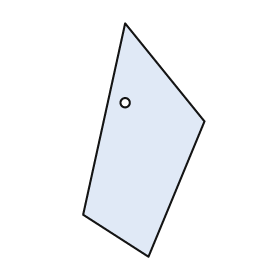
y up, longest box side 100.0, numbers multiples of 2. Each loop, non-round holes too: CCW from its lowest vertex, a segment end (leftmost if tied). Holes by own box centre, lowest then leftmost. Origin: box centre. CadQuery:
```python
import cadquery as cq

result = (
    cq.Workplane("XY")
    .moveTo(2.0, -50.0)
    .lineTo(26.0, 8.0)
    .lineTo(-8.0, 50.0)
    .lineTo(-26.0, -32.0)
    .close()
    .moveTo(-8.0, 16.0)
    .circle(2.0)
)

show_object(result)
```